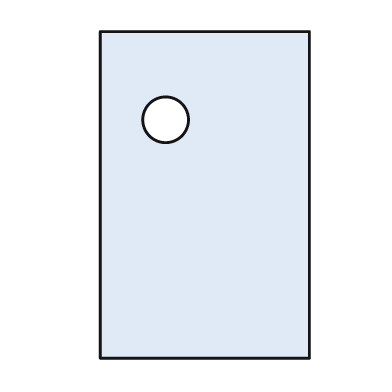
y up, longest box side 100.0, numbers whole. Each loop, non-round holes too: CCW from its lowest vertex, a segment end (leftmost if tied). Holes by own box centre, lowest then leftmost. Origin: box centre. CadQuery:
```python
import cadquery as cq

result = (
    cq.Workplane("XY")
    .moveTo(-32.0, -50.0)
    .lineTo(32.0, -50.0)
    .lineTo(32.0, 50.0)
    .lineTo(-32.0, 50.0)
    .close()
    .moveTo(-12.0, 23.0)
    .circle(7.0)
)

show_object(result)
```